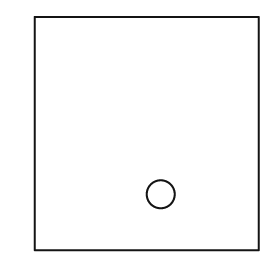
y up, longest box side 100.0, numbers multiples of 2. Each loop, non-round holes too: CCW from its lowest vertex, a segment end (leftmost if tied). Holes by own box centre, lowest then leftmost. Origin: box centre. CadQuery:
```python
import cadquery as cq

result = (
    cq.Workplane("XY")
    .moveTo(-48.0, -50.0)
    .lineTo(48.0, -50.0)
    .lineTo(48.0, 50.0)
    .lineTo(-48.0, 50.0)
    .close()
    .moveTo(6.0, -26.0)
    .circle(6.0)
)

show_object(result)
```